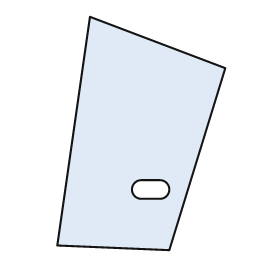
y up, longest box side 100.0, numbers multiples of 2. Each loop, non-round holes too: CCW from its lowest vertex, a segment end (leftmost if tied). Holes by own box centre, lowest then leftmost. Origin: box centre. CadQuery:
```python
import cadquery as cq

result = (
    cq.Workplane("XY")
    .moveTo(12.0, -50.0)
    .lineTo(36.0, 28.0)
    .lineTo(-22.0, 50.0)
    .lineTo(-36.0, -48.0)
    .close()
    .moveTo(0.0, -28.0)
    .lineTo(8.0, -28.0)
    .threePointArc((12.0, -24.0), (8.0, -20.0))
    .lineTo(0.0, -20.0)
    .threePointArc((-4.0, -24.0), (0.0, -28.0))
    .close()
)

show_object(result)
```